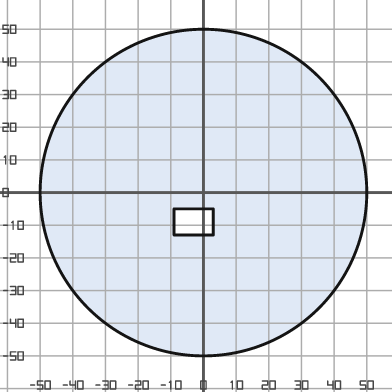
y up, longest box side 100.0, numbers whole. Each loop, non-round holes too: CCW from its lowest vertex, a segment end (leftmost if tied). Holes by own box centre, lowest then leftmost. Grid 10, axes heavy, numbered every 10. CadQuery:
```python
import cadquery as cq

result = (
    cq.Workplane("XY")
    .moveTo(0.0, 0.0)
    .circle(50.0)
    .moveTo(-9.0, -13.0)
    .lineTo(3.0, -13.0)
    .lineTo(3.0, -5.0)
    .lineTo(-9.0, -5.0)
    .close()
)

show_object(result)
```